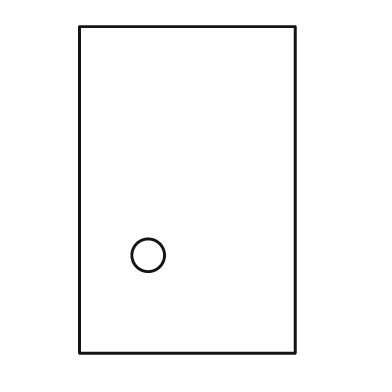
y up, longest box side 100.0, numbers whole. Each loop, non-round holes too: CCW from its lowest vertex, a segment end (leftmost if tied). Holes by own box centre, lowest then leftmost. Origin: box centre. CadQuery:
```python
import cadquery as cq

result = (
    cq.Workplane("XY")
    .moveTo(-33.0, -50.0)
    .lineTo(33.0, -50.0)
    .lineTo(33.0, 50.0)
    .lineTo(-33.0, 50.0)
    .close()
    .moveTo(-12.0, -20.0)
    .circle(5.0)
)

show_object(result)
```